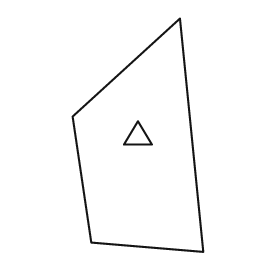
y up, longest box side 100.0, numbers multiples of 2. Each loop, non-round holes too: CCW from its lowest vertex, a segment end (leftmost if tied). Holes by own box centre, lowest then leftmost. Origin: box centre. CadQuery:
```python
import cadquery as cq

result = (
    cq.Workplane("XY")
    .moveTo(28.0, -50.0)
    .lineTo(18.0, 50.0)
    .lineTo(-28.0, 8.0)
    .lineTo(-20.0, -46.0)
    .close()
    .moveTo(-6.0, -4.0)
    .lineTo(6.0, -4.0)
    .lineTo(0.0, 6.0)
    .close()
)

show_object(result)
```